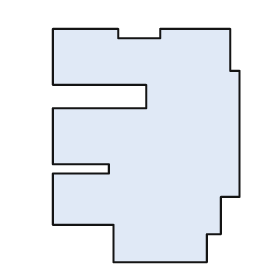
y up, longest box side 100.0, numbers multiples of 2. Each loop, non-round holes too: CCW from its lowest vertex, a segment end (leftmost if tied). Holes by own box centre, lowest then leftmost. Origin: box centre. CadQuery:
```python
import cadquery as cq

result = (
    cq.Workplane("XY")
    .moveTo(-14.0, -50.0)
    .lineTo(26.0, -50.0)
    .lineTo(26.0, -38.0)
    .lineTo(32.0, -38.0)
    .lineTo(32.0, -22.0)
    .lineTo(40.0, -22.0)
    .lineTo(40.0, 32.0)
    .lineTo(36.0, 32.0)
    .lineTo(36.0, 50.0)
    .lineTo(6.0, 50.0)
    .lineTo(6.0, 46.0)
    .lineTo(-12.0, 46.0)
    .lineTo(-12.0, 50.0)
    .lineTo(-40.0, 50.0)
    .lineTo(-40.0, 26.0)
    .lineTo(0.0, 26.0)
    .lineTo(0.0, 16.0)
    .lineTo(-40.0, 16.0)
    .lineTo(-40.0, -8.0)
    .lineTo(-16.0, -8.0)
    .lineTo(-16.0, -12.0)
    .lineTo(-40.0, -12.0)
    .lineTo(-40.0, -34.0)
    .lineTo(-14.0, -34.0)
    .close()
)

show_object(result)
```